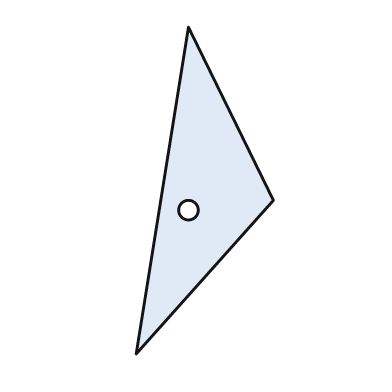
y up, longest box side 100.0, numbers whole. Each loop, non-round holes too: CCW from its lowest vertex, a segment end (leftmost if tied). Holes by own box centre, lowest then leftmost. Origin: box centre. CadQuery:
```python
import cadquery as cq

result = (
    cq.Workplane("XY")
    .moveTo(-21.0, -50.0)
    .lineTo(21.0, -3.0)
    .lineTo(-5.0, 50.0)
    .close()
    .moveTo(-5.0, -6.0)
    .circle(3.0)
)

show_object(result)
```